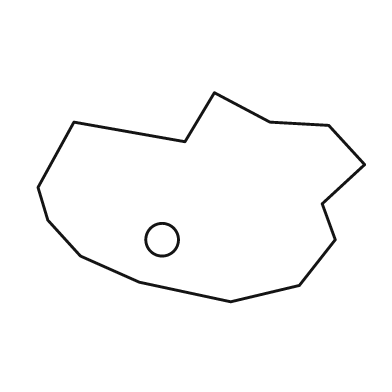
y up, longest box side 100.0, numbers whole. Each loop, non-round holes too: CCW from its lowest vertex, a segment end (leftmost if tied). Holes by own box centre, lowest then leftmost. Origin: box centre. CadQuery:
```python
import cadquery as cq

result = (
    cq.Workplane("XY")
    .moveTo(9.0, -32.0)
    .lineTo(30.0, -27.0)
    .lineTo(41.0, -13.0)
    .lineTo(37.0, -2.0)
    .lineTo(50.0, 10.0)
    .lineTo(39.0, 22.0)
    .lineTo(21.0, 23.0)
    .lineTo(4.0, 32.0)
    .lineTo(-5.0, 17.0)
    .lineTo(-39.0, 23.0)
    .lineTo(-50.0, 3.0)
    .lineTo(-47.0, -7.0)
    .lineTo(-37.0, -18.0)
    .lineTo(-19.0, -26.0)
    .close()
    .moveTo(-12.0, -13.0)
    .circle(5.0)
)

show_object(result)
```